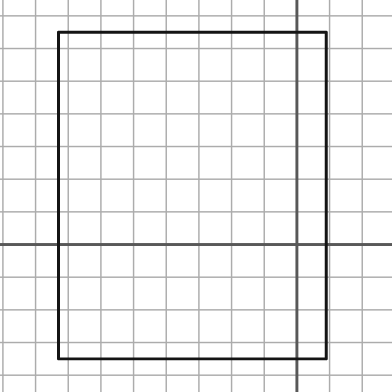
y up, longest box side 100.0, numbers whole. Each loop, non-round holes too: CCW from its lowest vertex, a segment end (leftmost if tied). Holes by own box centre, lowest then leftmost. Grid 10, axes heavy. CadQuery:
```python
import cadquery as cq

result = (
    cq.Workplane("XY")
    .moveTo(-73.0, -35.0)
    .lineTo(9.0, -35.0)
    .lineTo(9.0, 65.0)
    .lineTo(-73.0, 65.0)
    .close()
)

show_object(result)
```